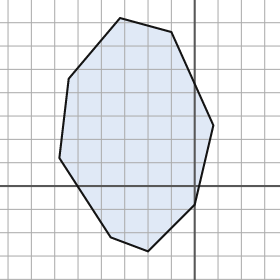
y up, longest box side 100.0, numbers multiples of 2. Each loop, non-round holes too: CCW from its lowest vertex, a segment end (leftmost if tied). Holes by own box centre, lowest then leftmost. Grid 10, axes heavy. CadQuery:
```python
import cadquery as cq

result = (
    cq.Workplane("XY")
    .moveTo(-20.0, -28.0)
    .lineTo(0.0, -8.0)
    .lineTo(8.0, 26.0)
    .lineTo(-10.0, 66.0)
    .lineTo(-32.0, 72.0)
    .lineTo(-54.0, 46.0)
    .lineTo(-58.0, 12.0)
    .lineTo(-36.0, -22.0)
    .close()
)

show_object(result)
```